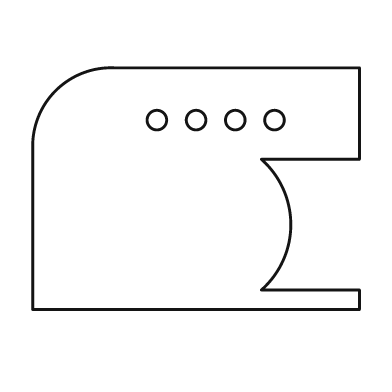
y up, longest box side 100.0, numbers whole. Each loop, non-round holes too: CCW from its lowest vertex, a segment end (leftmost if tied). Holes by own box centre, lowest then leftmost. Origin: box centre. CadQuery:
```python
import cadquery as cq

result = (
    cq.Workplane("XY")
    .moveTo(-50.0, -37.0)
    .lineTo(50.0, -37.0)
    .lineTo(50.0, -31.0)
    .lineTo(20.0, -31.0)
    .threePointArc((29.0, -11.0), (20.0, 9.0))
    .lineTo(50.0, 9.0)
    .lineTo(50.0, 37.0)
    .lineTo(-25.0, 37.0)
    .threePointArc((-43.0, 30.0), (-50.0, 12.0))
    .close()
    .moveTo(-12.0, 21.0)
    .circle(3.0)
    .moveTo(0.0, 21.0)
    .circle(3.0)
    .moveTo(12.0, 21.0)
    .circle(3.0)
    .moveTo(24.0, 21.0)
    .circle(3.0)
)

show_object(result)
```